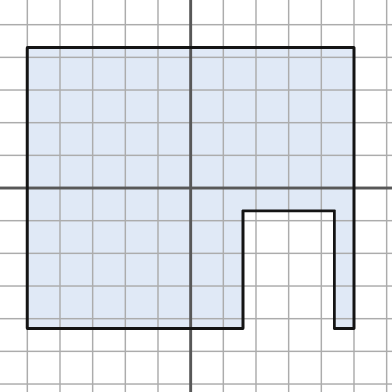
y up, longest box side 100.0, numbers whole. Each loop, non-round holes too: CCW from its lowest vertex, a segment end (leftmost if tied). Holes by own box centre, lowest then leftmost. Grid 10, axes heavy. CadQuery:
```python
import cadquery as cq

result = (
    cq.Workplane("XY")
    .moveTo(-50.0, -43.0)
    .lineTo(16.0, -43.0)
    .lineTo(16.0, -7.0)
    .lineTo(44.0, -7.0)
    .lineTo(44.0, -43.0)
    .lineTo(50.0, -43.0)
    .lineTo(50.0, 43.0)
    .lineTo(-50.0, 43.0)
    .close()
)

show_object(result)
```